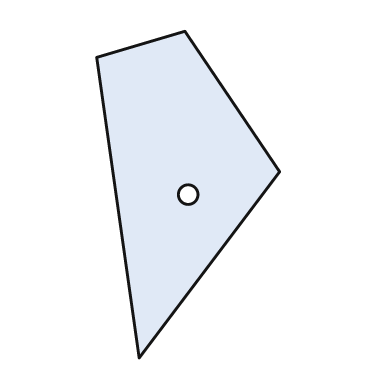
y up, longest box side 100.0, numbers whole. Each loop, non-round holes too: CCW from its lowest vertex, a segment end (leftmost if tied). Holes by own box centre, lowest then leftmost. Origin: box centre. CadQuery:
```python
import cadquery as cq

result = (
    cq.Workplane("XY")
    .moveTo(-15.0, -50.0)
    .lineTo(28.0, 7.0)
    .lineTo(-1.0, 50.0)
    .lineTo(-28.0, 42.0)
    .close()
    .moveTo(0.0, 0.0)
    .circle(3.0)
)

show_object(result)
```